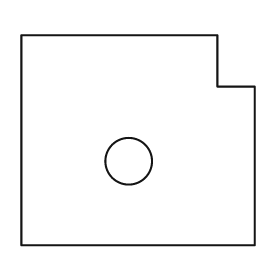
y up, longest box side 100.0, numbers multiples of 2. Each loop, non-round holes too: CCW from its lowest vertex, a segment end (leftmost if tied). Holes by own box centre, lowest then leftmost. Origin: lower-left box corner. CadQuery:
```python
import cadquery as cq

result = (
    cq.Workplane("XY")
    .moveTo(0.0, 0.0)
    .lineTo(100.0, 0.0)
    .lineTo(100.0, 68.0)
    .lineTo(84.0, 68.0)
    .lineTo(84.0, 90.0)
    .lineTo(0.0, 90.0)
    .close()
    .moveTo(46.0, 36.0)
    .circle(10.0)
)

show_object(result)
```